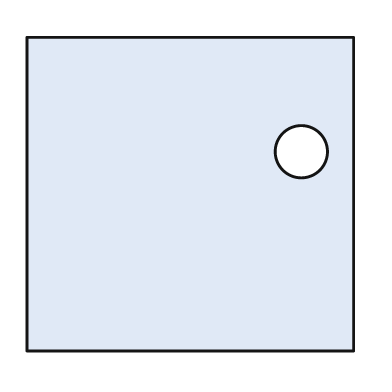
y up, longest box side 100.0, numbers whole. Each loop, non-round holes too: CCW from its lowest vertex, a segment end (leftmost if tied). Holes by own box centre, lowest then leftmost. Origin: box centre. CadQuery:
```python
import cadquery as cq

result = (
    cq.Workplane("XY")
    .moveTo(-50.0, -48.0)
    .lineTo(50.0, -48.0)
    .lineTo(50.0, 48.0)
    .lineTo(-50.0, 48.0)
    .close()
    .moveTo(34.0, 13.0)
    .circle(8.0)
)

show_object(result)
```